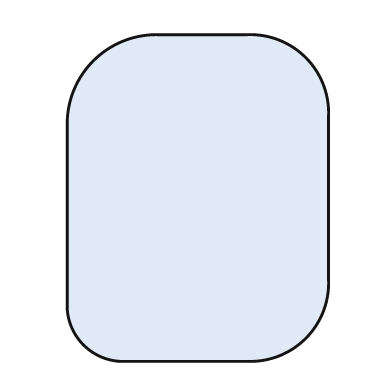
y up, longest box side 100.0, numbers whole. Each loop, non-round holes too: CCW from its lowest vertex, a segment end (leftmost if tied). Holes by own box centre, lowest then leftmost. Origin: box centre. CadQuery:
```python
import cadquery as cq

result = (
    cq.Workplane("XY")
    .moveTo(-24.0, -50.0)
    .lineTo(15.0, -50.0)
    .threePointArc((33.0, -43.0), (40.0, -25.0))
    .lineTo(40.0, 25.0)
    .threePointArc((33.0, 43.0), (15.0, 50.0))
    .lineTo(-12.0, 50.0)
    .threePointArc((-32.0, 42.0), (-40.0, 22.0))
    .lineTo(-40.0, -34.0)
    .threePointArc((-35.0, -45.0), (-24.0, -50.0))
    .close()
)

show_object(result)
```